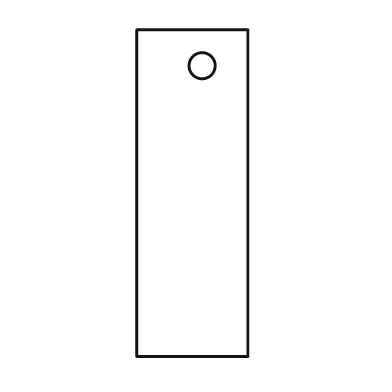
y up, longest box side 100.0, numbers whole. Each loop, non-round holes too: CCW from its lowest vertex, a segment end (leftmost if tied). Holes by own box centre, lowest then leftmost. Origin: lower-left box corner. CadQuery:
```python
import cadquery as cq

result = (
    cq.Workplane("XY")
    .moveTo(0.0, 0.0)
    .lineTo(34.0, 0.0)
    .lineTo(34.0, 100.0)
    .lineTo(0.0, 100.0)
    .close()
    .moveTo(20.0, 89.0)
    .circle(4.0)
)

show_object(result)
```